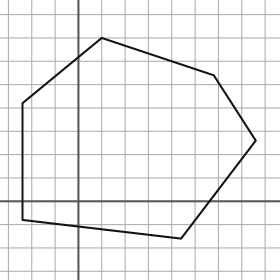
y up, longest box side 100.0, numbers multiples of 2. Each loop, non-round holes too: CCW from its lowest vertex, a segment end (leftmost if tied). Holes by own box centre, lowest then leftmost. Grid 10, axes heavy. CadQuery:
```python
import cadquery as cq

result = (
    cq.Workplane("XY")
    .moveTo(44.0, -16.0)
    .lineTo(76.0, 26.0)
    .lineTo(58.0, 54.0)
    .lineTo(10.0, 70.0)
    .lineTo(-24.0, 42.0)
    .lineTo(-24.0, -8.0)
    .close()
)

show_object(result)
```